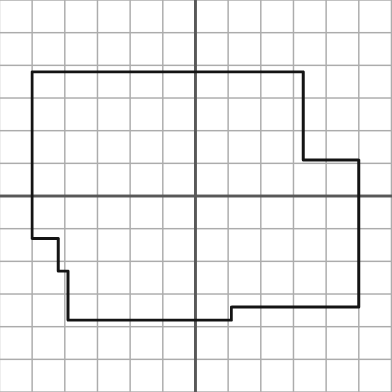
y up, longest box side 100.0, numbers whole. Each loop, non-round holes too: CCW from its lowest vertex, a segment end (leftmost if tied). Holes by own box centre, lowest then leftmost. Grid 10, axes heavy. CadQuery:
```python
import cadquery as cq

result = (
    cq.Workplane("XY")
    .moveTo(-39.0, -38.0)
    .lineTo(11.0, -38.0)
    .lineTo(11.0, -34.0)
    .lineTo(50.0, -34.0)
    .lineTo(50.0, 11.0)
    .lineTo(33.0, 11.0)
    .lineTo(33.0, 38.0)
    .lineTo(-50.0, 38.0)
    .lineTo(-50.0, -13.0)
    .lineTo(-42.0, -13.0)
    .lineTo(-42.0, -23.0)
    .lineTo(-39.0, -23.0)
    .close()
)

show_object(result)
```